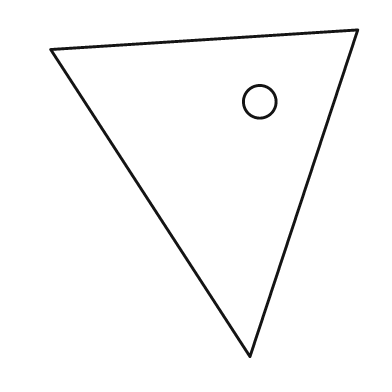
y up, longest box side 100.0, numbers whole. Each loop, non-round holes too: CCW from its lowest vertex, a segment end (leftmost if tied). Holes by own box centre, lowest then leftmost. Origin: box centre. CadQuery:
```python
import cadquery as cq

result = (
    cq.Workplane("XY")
    .moveTo(14.0, -50.0)
    .lineTo(47.0, 50.0)
    .lineTo(-47.0, 44.0)
    .close()
    .moveTo(17.0, 28.0)
    .circle(5.0)
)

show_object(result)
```